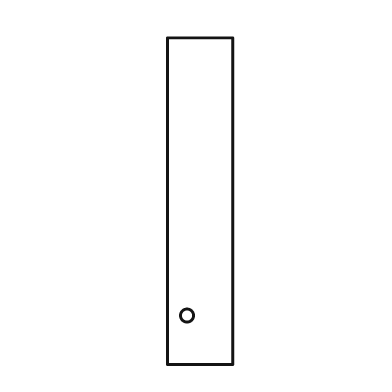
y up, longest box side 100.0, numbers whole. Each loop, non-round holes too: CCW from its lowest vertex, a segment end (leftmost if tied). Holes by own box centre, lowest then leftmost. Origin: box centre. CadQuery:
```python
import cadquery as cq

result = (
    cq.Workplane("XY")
    .moveTo(-10.0, -50.0)
    .lineTo(10.0, -50.0)
    .lineTo(10.0, 50.0)
    .lineTo(-10.0, 50.0)
    .close()
    .moveTo(-4.0, -35.0)
    .circle(2.0)
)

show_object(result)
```